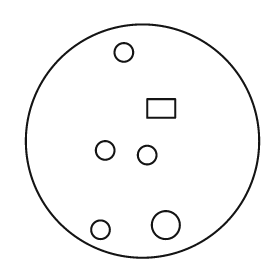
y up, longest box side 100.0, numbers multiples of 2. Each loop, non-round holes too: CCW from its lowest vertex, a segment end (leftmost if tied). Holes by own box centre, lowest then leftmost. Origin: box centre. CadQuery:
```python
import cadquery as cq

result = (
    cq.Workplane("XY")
    .moveTo(0.0, 0.0)
    .circle(50.0)
    .moveTo(-18.0, -38.0)
    .circle(4.0)
    .moveTo(10.0, -36.0)
    .circle(6.0)
    .moveTo(2.0, -6.0)
    .circle(4.0)
    .moveTo(-16.0, -4.0)
    .circle(4.0)
    .moveTo(2.0, 10.0)
    .lineTo(14.0, 10.0)
    .lineTo(14.0, 18.0)
    .lineTo(2.0, 18.0)
    .close()
    .moveTo(-8.0, 38.0)
    .circle(4.0)
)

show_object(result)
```